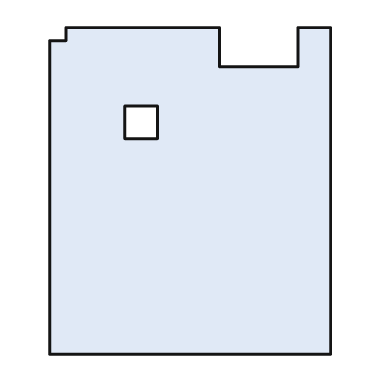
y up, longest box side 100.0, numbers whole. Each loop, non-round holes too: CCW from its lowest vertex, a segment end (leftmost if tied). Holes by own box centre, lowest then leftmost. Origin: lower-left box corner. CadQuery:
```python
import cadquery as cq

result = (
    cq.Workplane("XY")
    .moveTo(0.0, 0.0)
    .lineTo(86.0, 0.0)
    .lineTo(86.0, 100.0)
    .lineTo(76.0, 100.0)
    .lineTo(76.0, 88.0)
    .lineTo(52.0, 88.0)
    .lineTo(52.0, 100.0)
    .lineTo(5.0, 100.0)
    .lineTo(5.0, 96.0)
    .lineTo(0.0, 96.0)
    .close()
    .moveTo(23.0, 66.0)
    .lineTo(33.0, 66.0)
    .lineTo(33.0, 76.0)
    .lineTo(23.0, 76.0)
    .close()
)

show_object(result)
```